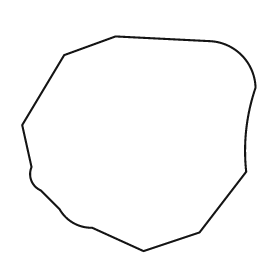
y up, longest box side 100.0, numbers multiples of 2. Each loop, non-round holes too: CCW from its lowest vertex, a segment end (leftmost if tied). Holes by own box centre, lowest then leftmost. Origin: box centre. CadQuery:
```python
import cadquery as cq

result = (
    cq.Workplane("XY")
    .moveTo(2.0, -46.0)
    .lineTo(26.0, -38.0)
    .lineTo(46.0, -12.0)
    .threePointArc((46.0, 6.0), (50.0, 24.0))
    .threePointArc((44.0, 38.0), (30.0, 44.0))
    .lineTo(-10.0, 46.0)
    .lineTo(-32.0, 38.0)
    .lineTo(-50.0, 8.0)
    .lineTo(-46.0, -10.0)
    .threePointArc((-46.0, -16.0), (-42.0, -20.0))
    .lineTo(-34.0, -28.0)
    .threePointArc((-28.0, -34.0), (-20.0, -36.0))
    .close()
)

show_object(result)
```